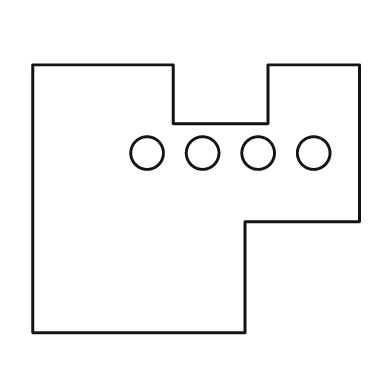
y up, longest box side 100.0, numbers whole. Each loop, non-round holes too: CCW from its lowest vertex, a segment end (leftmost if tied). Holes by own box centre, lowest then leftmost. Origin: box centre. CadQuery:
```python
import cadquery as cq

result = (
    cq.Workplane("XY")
    .moveTo(-50.0, -41.0)
    .lineTo(15.0, -41.0)
    .lineTo(15.0, -7.0)
    .lineTo(50.0, -7.0)
    .lineTo(50.0, 41.0)
    .lineTo(22.0, 41.0)
    .lineTo(22.0, 23.0)
    .lineTo(-7.0, 23.0)
    .lineTo(-7.0, 41.0)
    .lineTo(-50.0, 41.0)
    .close()
    .moveTo(-15.0, 14.0)
    .circle(5.0)
    .moveTo(2.0, 14.0)
    .circle(5.0)
    .moveTo(19.0, 14.0)
    .circle(5.0)
    .moveTo(36.0, 14.0)
    .circle(5.0)
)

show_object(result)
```